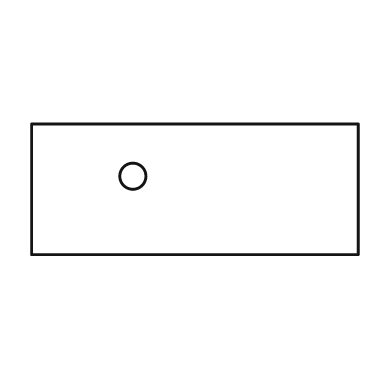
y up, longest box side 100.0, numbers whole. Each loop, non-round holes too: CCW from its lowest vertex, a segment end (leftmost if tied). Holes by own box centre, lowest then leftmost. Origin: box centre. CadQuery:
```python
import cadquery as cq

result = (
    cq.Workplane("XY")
    .moveTo(-50.0, -20.0)
    .lineTo(50.0, -20.0)
    .lineTo(50.0, 20.0)
    .lineTo(-50.0, 20.0)
    .close()
    .moveTo(-19.0, 4.0)
    .circle(4.0)
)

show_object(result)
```